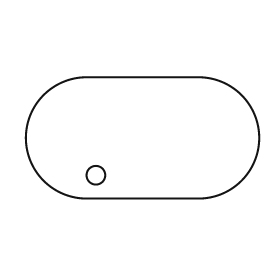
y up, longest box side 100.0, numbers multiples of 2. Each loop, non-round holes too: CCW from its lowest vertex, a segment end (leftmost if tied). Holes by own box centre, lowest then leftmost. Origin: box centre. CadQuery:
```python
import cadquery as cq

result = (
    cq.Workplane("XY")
    .moveTo(-24.0, -26.0)
    .lineTo(24.0, -26.0)
    .threePointArc((50.0, 0.0), (24.0, 26.0))
    .lineTo(-24.0, 26.0)
    .threePointArc((-50.0, 0.0), (-24.0, -26.0))
    .close()
    .moveTo(-20.0, -16.0)
    .circle(4.0)
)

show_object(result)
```